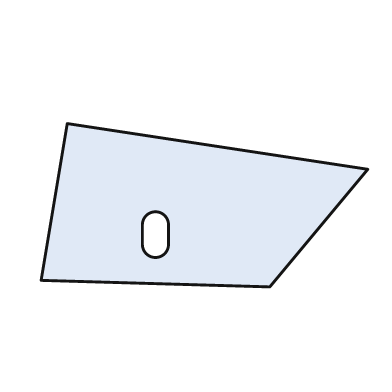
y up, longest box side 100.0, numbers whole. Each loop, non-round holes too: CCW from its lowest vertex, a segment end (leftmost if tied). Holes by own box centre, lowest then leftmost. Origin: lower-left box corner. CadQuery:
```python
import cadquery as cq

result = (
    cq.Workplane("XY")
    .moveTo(70.0, 0.0)
    .lineTo(100.0, 36.0)
    .lineTo(8.0, 50.0)
    .lineTo(0.0, 2.0)
    .close()
    .moveTo(31.0, 13.0)
    .threePointArc((35.0, 9.0), (39.0, 13.0))
    .lineTo(39.0, 19.0)
    .threePointArc((35.0, 23.0), (31.0, 19.0))
    .close()
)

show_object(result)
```